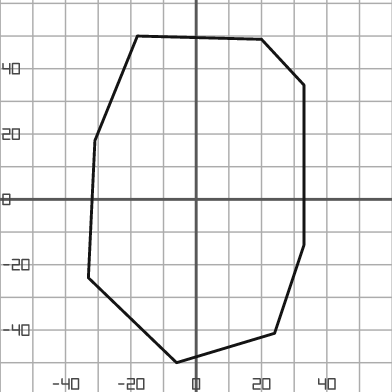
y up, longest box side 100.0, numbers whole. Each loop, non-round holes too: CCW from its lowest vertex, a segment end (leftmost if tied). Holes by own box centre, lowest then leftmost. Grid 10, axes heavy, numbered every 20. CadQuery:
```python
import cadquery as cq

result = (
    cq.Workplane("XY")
    .moveTo(-6.0, -50.0)
    .lineTo(24.0, -41.0)
    .lineTo(33.0, -14.0)
    .lineTo(33.0, 35.0)
    .lineTo(20.0, 49.0)
    .lineTo(-18.0, 50.0)
    .lineTo(-31.0, 18.0)
    .lineTo(-33.0, -24.0)
    .close()
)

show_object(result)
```